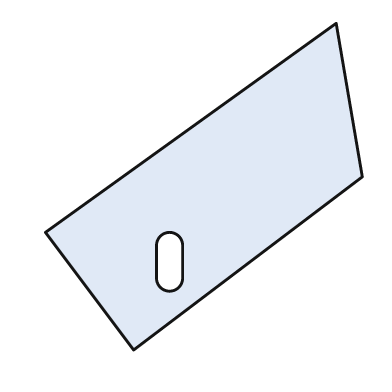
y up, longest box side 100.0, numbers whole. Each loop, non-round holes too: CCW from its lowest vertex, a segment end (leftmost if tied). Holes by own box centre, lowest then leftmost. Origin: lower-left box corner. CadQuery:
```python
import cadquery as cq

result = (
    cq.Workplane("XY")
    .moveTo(27.0, 0.0)
    .lineTo(97.0, 53.0)
    .lineTo(89.0, 100.0)
    .lineTo(0.0, 36.0)
    .close()
    .moveTo(34.0, 22.0)
    .threePointArc((38.0, 18.0), (42.0, 22.0))
    .lineTo(42.0, 32.0)
    .threePointArc((38.0, 36.0), (34.0, 32.0))
    .close()
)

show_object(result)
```